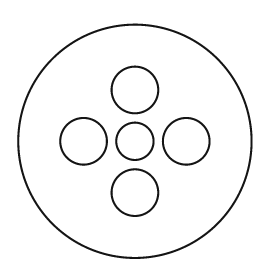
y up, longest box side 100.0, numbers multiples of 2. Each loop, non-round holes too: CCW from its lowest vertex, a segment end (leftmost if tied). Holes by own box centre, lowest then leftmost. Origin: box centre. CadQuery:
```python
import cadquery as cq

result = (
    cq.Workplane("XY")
    .moveTo(0.0, 0.0)
    .circle(50.0)
    .moveTo(0.0, -22.0)
    .circle(10.0)
    .moveTo(-22.0, 0.0)
    .circle(10.0)
    .moveTo(0.0, 0.0)
    .circle(8.0)
    .moveTo(22.0, 0.0)
    .circle(10.0)
    .moveTo(0.0, 22.0)
    .circle(10.0)
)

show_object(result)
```